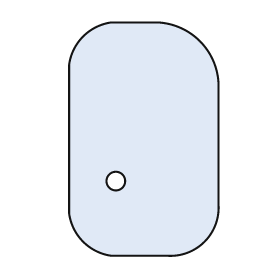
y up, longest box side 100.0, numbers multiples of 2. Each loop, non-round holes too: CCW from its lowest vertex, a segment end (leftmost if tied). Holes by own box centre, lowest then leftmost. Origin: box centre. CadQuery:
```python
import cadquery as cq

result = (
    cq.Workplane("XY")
    .moveTo(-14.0, -50.0)
    .lineTo(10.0, -50.0)
    .threePointArc((26.0, -44.0), (32.0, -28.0))
    .lineTo(32.0, 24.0)
    .threePointArc((24.0, 42.0), (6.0, 50.0))
    .lineTo(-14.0, 50.0)
    .threePointArc((-26.0, 44.0), (-32.0, 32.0))
    .lineTo(-32.0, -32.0)
    .threePointArc((-26.0, -44.0), (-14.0, -50.0))
    .close()
    .moveTo(-12.0, -18.0)
    .circle(4.0)
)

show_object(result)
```